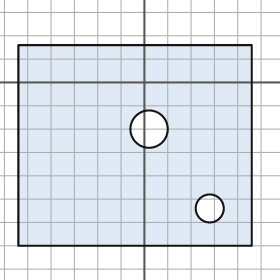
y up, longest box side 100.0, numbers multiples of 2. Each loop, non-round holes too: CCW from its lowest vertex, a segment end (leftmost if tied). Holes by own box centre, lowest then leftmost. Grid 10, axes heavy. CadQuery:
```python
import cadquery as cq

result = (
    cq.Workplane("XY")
    .moveTo(-54.0, -70.0)
    .lineTo(46.0, -70.0)
    .lineTo(46.0, 16.0)
    .lineTo(-54.0, 16.0)
    .close()
    .moveTo(28.0, -54.0)
    .circle(6.0)
    .moveTo(2.0, -20.0)
    .circle(8.0)
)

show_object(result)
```